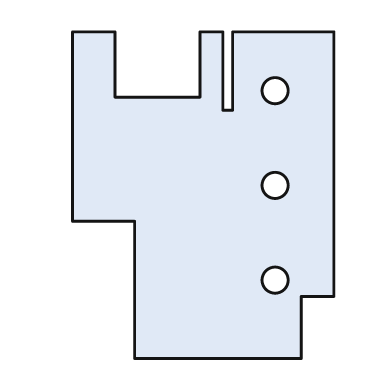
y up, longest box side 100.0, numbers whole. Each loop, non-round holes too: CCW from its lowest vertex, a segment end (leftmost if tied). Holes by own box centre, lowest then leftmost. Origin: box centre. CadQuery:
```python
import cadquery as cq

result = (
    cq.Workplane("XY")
    .moveTo(-21.0, -50.0)
    .lineTo(30.0, -50.0)
    .lineTo(30.0, -31.0)
    .lineTo(40.0, -31.0)
    .lineTo(40.0, 50.0)
    .lineTo(9.0, 50.0)
    .lineTo(9.0, 26.0)
    .lineTo(6.0, 26.0)
    .lineTo(6.0, 50.0)
    .lineTo(-1.0, 50.0)
    .lineTo(-1.0, 30.0)
    .lineTo(-27.0, 30.0)
    .lineTo(-27.0, 50.0)
    .lineTo(-40.0, 50.0)
    .lineTo(-40.0, -8.0)
    .lineTo(-21.0, -8.0)
    .close()
    .moveTo(22.0, -26.0)
    .circle(4.0)
    .moveTo(22.0, 3.0)
    .circle(4.0)
    .moveTo(22.0, 32.0)
    .circle(4.0)
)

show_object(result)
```